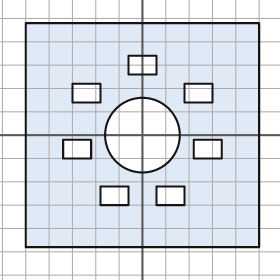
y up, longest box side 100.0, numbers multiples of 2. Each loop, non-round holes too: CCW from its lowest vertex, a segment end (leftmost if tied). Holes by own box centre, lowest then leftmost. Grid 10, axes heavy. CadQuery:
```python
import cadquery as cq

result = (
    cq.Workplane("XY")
    .moveTo(-50.0, -48.0)
    .lineTo(50.0, -48.0)
    .lineTo(50.0, 48.0)
    .lineTo(-50.0, 48.0)
    .close()
    .moveTo(-18.0, -30.0)
    .lineTo(-6.0, -30.0)
    .lineTo(-6.0, -22.0)
    .lineTo(-18.0, -22.0)
    .close()
    .moveTo(6.0, -30.0)
    .lineTo(18.0, -30.0)
    .lineTo(18.0, -22.0)
    .lineTo(6.0, -22.0)
    .close()
    .moveTo(-34.0, -10.0)
    .lineTo(-22.0, -10.0)
    .lineTo(-22.0, -2.0)
    .lineTo(-34.0, -2.0)
    .close()
    .moveTo(22.0, -10.0)
    .lineTo(34.0, -10.0)
    .lineTo(34.0, -2.0)
    .lineTo(22.0, -2.0)
    .close()
    .moveTo(0.0, 0.0)
    .circle(16.0)
    .moveTo(-30.0, 14.0)
    .lineTo(-18.0, 14.0)
    .lineTo(-18.0, 22.0)
    .lineTo(-30.0, 22.0)
    .close()
    .moveTo(18.0, 14.0)
    .lineTo(30.0, 14.0)
    .lineTo(30.0, 22.0)
    .lineTo(18.0, 22.0)
    .close()
    .moveTo(-6.0, 26.0)
    .lineTo(6.0, 26.0)
    .lineTo(6.0, 34.0)
    .lineTo(-6.0, 34.0)
    .close()
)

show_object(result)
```